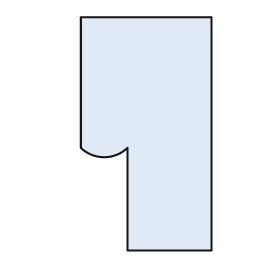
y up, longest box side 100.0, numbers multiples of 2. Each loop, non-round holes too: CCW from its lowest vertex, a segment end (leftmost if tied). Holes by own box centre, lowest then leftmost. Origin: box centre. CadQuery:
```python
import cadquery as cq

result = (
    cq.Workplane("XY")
    .moveTo(-8.0, -50.0)
    .lineTo(28.0, -50.0)
    .lineTo(28.0, 50.0)
    .lineTo(-28.0, 50.0)
    .lineTo(-28.0, -6.0)
    .threePointArc((-18.0, -10.0), (-8.0, -6.0))
    .close()
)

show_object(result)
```